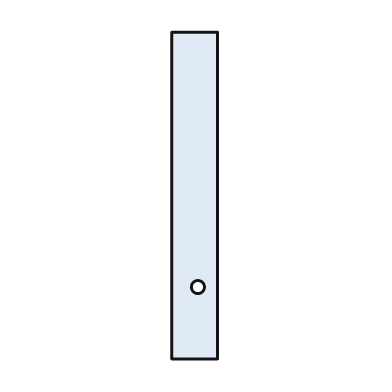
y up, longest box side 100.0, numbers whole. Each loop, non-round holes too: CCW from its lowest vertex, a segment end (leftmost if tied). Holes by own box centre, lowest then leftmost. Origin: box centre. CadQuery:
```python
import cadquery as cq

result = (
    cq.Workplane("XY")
    .moveTo(-7.0, -50.0)
    .lineTo(7.0, -50.0)
    .lineTo(7.0, 50.0)
    .lineTo(-7.0, 50.0)
    .close()
    .moveTo(1.0, -28.0)
    .circle(2.0)
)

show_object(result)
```